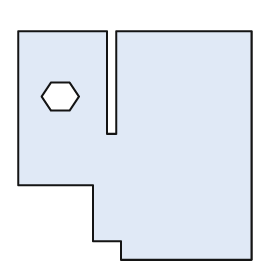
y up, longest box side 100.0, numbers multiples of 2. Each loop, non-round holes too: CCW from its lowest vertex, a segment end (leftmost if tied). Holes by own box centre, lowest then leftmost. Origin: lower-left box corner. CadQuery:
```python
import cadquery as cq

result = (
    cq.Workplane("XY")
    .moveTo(44.0, 0.0)
    .lineTo(100.0, 0.0)
    .lineTo(100.0, 98.0)
    .lineTo(42.0, 98.0)
    .lineTo(42.0, 54.0)
    .lineTo(38.0, 54.0)
    .lineTo(38.0, 98.0)
    .lineTo(0.0, 98.0)
    .lineTo(0.0, 32.0)
    .lineTo(32.0, 32.0)
    .lineTo(32.0, 8.0)
    .lineTo(44.0, 8.0)
    .close()
    .moveTo(14.0, 64.0)
    .lineTo(22.0, 64.0)
    .lineTo(26.0, 70.0)
    .lineTo(22.0, 76.0)
    .lineTo(14.0, 76.0)
    .lineTo(10.0, 70.0)
    .close()
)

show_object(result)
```